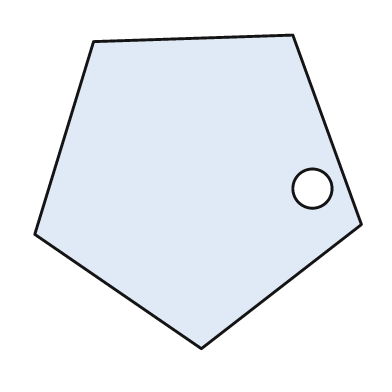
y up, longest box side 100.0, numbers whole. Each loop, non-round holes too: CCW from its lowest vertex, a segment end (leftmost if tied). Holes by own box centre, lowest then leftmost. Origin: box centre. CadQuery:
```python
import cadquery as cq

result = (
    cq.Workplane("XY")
    .moveTo(1.0, -48.0)
    .lineTo(50.0, -10.0)
    .lineTo(29.0, 48.0)
    .lineTo(-32.0, 46.0)
    .lineTo(-50.0, -13.0)
    .close()
    .moveTo(35.0, 1.0)
    .circle(6.0)
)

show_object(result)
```